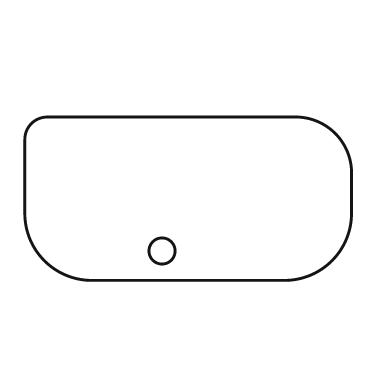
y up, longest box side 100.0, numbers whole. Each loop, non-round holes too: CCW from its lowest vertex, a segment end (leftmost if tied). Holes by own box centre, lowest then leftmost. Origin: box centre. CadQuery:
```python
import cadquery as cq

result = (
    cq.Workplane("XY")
    .moveTo(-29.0, -25.0)
    .lineTo(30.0, -25.0)
    .threePointArc((44.0, -19.0), (50.0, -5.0))
    .lineTo(50.0, 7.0)
    .threePointArc((45.0, 20.0), (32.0, 25.0))
    .lineTo(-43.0, 25.0)
    .threePointArc((-48.0, 23.0), (-50.0, 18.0))
    .lineTo(-50.0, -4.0)
    .threePointArc((-44.0, -19.0), (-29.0, -25.0))
    .close()
    .moveTo(-8.0, -16.0)
    .circle(4.0)
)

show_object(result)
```